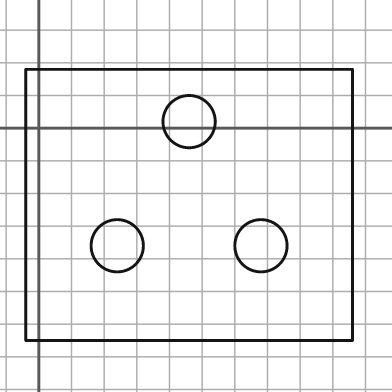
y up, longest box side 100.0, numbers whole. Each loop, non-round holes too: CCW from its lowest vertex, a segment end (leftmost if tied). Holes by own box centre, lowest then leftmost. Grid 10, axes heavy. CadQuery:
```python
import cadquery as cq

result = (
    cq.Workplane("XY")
    .moveTo(-4.0, -65.0)
    .lineTo(96.0, -65.0)
    .lineTo(96.0, 18.0)
    .lineTo(-4.0, 18.0)
    .close()
    .moveTo(24.0, -36.0)
    .circle(8.0)
    .moveTo(68.0, -36.0)
    .circle(8.0)
    .moveTo(46.0, 2.0)
    .circle(8.0)
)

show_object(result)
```